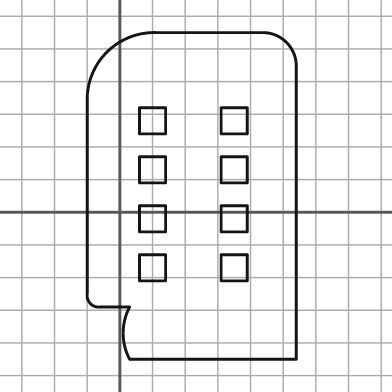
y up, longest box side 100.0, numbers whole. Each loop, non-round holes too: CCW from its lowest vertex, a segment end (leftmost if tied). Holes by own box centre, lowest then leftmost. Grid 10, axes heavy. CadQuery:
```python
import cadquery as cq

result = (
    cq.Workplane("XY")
    .moveTo(3.0, -45.0)
    .lineTo(54.0, -45.0)
    .lineTo(54.0, 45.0)
    .threePointArc((51.0, 52.0), (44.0, 55.0))
    .lineTo(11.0, 55.0)
    .threePointArc((-4.0, 49.0), (-10.0, 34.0))
    .lineTo(-10.0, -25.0)
    .threePointArc((-9.0, -28.0), (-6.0, -29.0))
    .lineTo(3.0, -29.0)
    .threePointArc((1.0, -37.0), (3.0, -45.0))
    .close()
    .moveTo(6.0, -21.0)
    .lineTo(14.0, -21.0)
    .lineTo(14.0, -13.0)
    .lineTo(6.0, -13.0)
    .close()
    .moveTo(31.0, -21.0)
    .lineTo(39.0, -21.0)
    .lineTo(39.0, -13.0)
    .lineTo(31.0, -13.0)
    .close()
    .moveTo(6.0, -6.0)
    .lineTo(14.0, -6.0)
    .lineTo(14.0, 2.0)
    .lineTo(6.0, 2.0)
    .close()
    .moveTo(31.0, -6.0)
    .lineTo(39.0, -6.0)
    .lineTo(39.0, 2.0)
    .lineTo(31.0, 2.0)
    .close()
    .moveTo(6.0, 9.0)
    .lineTo(14.0, 9.0)
    .lineTo(14.0, 17.0)
    .lineTo(6.0, 17.0)
    .close()
    .moveTo(31.0, 9.0)
    .lineTo(39.0, 9.0)
    .lineTo(39.0, 17.0)
    .lineTo(31.0, 17.0)
    .close()
    .moveTo(6.0, 24.0)
    .lineTo(14.0, 24.0)
    .lineTo(14.0, 32.0)
    .lineTo(6.0, 32.0)
    .close()
    .moveTo(31.0, 24.0)
    .lineTo(39.0, 24.0)
    .lineTo(39.0, 32.0)
    .lineTo(31.0, 32.0)
    .close()
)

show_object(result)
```